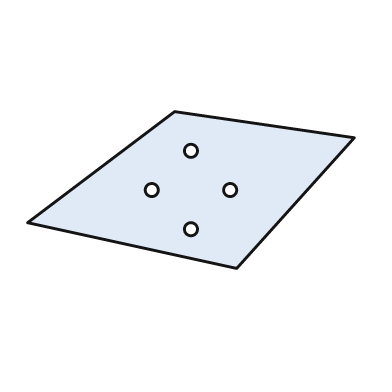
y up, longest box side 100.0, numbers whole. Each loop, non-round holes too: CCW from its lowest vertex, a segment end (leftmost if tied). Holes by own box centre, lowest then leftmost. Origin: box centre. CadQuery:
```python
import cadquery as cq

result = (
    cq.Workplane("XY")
    .moveTo(14.0, -24.0)
    .lineTo(50.0, 16.0)
    .lineTo(-5.0, 24.0)
    .lineTo(-50.0, -10.0)
    .close()
    .moveTo(0.0, -12.0)
    .circle(2.0)
    .moveTo(-12.0, 0.0)
    .circle(2.0)
    .moveTo(12.0, 0.0)
    .circle(2.0)
    .moveTo(0.0, 12.0)
    .circle(2.0)
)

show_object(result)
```